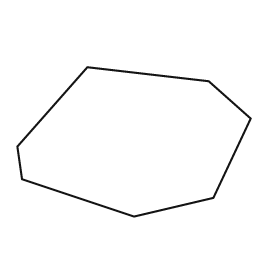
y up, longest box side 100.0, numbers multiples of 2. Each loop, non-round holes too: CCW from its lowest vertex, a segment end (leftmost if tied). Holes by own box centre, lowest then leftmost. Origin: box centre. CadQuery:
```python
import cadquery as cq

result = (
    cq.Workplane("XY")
    .moveTo(0.0, -32.0)
    .lineTo(34.0, -24.0)
    .lineTo(50.0, 10.0)
    .lineTo(32.0, 26.0)
    .lineTo(-20.0, 32.0)
    .lineTo(-50.0, -2.0)
    .lineTo(-48.0, -16.0)
    .close()
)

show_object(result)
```